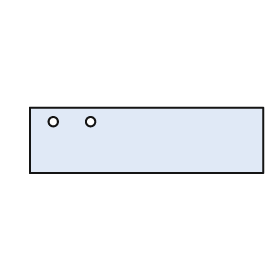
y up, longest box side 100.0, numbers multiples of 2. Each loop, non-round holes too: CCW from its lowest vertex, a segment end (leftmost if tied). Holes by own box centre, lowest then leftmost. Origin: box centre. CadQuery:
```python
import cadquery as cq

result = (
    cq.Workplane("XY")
    .moveTo(-50.0, -14.0)
    .lineTo(50.0, -14.0)
    .lineTo(50.0, 14.0)
    .lineTo(-50.0, 14.0)
    .close()
    .moveTo(-40.0, 8.0)
    .circle(2.0)
    .moveTo(-24.0, 8.0)
    .circle(2.0)
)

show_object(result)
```